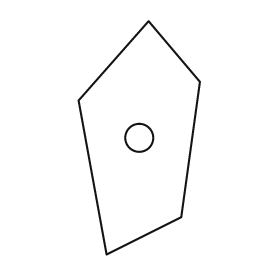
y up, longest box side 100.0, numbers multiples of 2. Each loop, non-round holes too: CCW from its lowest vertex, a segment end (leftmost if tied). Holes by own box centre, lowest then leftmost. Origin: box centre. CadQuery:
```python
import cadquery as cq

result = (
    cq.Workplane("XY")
    .moveTo(-14.0, -50.0)
    .lineTo(18.0, -34.0)
    .lineTo(26.0, 24.0)
    .lineTo(4.0, 50.0)
    .lineTo(-26.0, 16.0)
    .close()
    .moveTo(0.0, 0.0)
    .circle(6.0)
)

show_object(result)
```